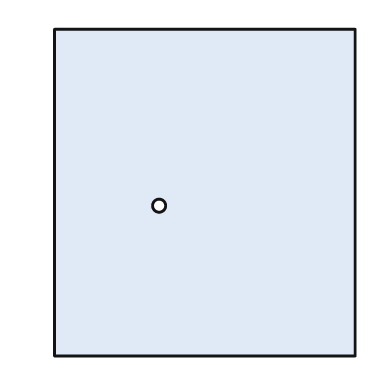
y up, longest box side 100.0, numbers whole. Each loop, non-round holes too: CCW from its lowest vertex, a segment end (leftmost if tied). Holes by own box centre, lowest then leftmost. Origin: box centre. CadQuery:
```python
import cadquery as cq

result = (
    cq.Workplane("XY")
    .moveTo(-46.0, -50.0)
    .lineTo(46.0, -50.0)
    .lineTo(46.0, 50.0)
    .lineTo(-46.0, 50.0)
    .close()
    .moveTo(-14.0, -4.0)
    .circle(2.0)
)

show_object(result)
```